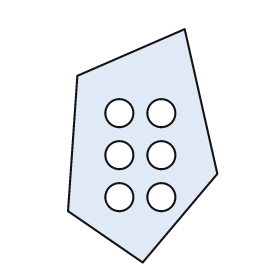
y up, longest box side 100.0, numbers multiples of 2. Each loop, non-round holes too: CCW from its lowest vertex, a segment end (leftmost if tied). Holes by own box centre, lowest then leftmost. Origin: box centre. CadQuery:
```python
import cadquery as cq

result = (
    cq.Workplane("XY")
    .moveTo(0.0, -50.0)
    .lineTo(32.0, -12.0)
    .lineTo(18.0, 50.0)
    .lineTo(-28.0, 30.0)
    .lineTo(-32.0, -28.0)
    .close()
    .moveTo(-10.0, -22.0)
    .circle(6.0)
    .moveTo(8.0, -22.0)
    .circle(6.0)
    .moveTo(-10.0, -4.0)
    .circle(6.0)
    .moveTo(8.0, -4.0)
    .circle(6.0)
    .moveTo(-10.0, 14.0)
    .circle(6.0)
    .moveTo(8.0, 14.0)
    .circle(6.0)
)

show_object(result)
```